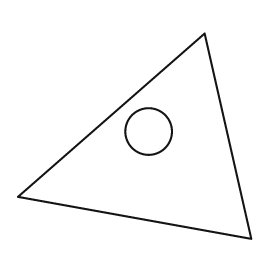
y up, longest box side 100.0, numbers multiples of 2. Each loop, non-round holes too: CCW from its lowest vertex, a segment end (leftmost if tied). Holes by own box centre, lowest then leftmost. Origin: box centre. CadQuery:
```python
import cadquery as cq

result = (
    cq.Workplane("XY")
    .moveTo(50.0, -44.0)
    .lineTo(30.0, 44.0)
    .lineTo(-50.0, -26.0)
    .close()
    .moveTo(6.0, 2.0)
    .circle(10.0)
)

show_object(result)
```